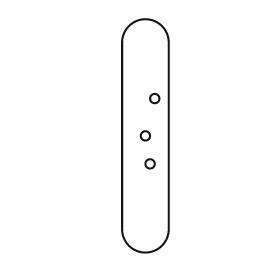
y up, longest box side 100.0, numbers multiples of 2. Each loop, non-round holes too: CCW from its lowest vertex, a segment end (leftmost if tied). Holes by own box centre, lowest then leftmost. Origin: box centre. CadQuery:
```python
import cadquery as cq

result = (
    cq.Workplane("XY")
    .moveTo(-10.0, -40.0)
    .threePointArc((0.0, -50.0), (10.0, -40.0))
    .lineTo(10.0, 40.0)
    .threePointArc((0.0, 50.0), (-10.0, 40.0))
    .close()
    .moveTo(2.0, -12.0)
    .circle(2.0)
    .moveTo(0.0, 0.0)
    .circle(2.0)
    .moveTo(4.0, 16.0)
    .circle(2.0)
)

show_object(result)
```